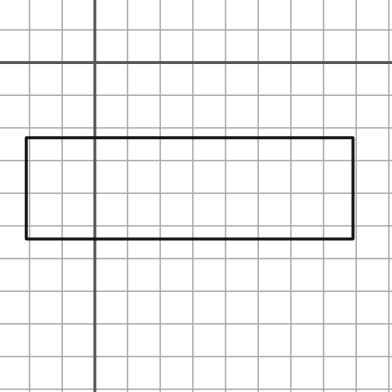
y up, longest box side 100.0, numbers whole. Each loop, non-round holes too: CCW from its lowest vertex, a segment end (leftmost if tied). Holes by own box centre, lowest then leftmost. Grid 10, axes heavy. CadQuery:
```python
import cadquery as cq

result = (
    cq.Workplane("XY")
    .moveTo(-21.0, -54.0)
    .lineTo(79.0, -54.0)
    .lineTo(79.0, -23.0)
    .lineTo(-21.0, -23.0)
    .close()
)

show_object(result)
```